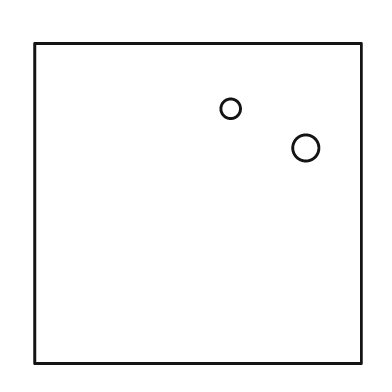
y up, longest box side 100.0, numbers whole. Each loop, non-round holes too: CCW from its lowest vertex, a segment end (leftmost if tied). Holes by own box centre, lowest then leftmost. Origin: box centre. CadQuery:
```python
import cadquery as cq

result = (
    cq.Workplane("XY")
    .moveTo(-50.0, -49.0)
    .lineTo(50.0, -49.0)
    .lineTo(50.0, 49.0)
    .lineTo(-50.0, 49.0)
    .close()
    .moveTo(33.0, 17.0)
    .circle(4.0)
    .moveTo(10.0, 29.0)
    .circle(3.0)
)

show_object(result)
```